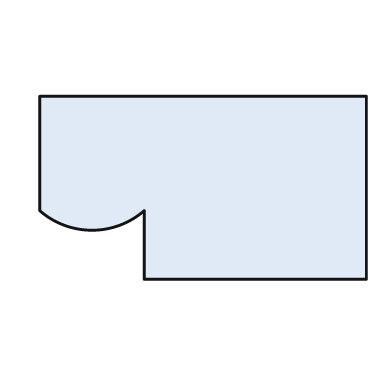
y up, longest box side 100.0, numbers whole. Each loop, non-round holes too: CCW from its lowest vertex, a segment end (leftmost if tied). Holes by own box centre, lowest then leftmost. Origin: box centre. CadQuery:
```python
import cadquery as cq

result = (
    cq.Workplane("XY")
    .moveTo(-18.0, -28.0)
    .lineTo(50.0, -28.0)
    .lineTo(50.0, 28.0)
    .lineTo(-50.0, 28.0)
    .lineTo(-50.0, -7.0)
    .threePointArc((-34.0, -13.0), (-18.0, -7.0))
    .close()
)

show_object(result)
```